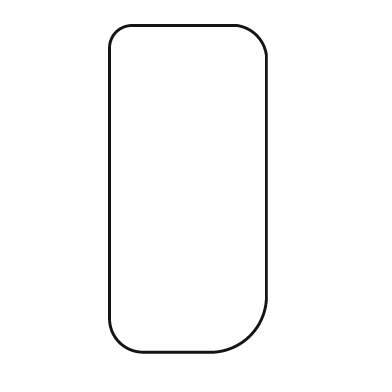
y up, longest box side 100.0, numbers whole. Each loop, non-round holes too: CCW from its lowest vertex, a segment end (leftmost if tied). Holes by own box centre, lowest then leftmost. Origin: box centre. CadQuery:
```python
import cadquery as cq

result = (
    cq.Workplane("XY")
    .moveTo(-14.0, -50.0)
    .lineTo(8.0, -50.0)
    .threePointArc((19.0, -45.0), (24.0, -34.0))
    .lineTo(24.0, 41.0)
    .threePointArc((21.0, 47.0), (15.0, 50.0))
    .lineTo(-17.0, 50.0)
    .threePointArc((-22.0, 48.0), (-24.0, 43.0))
    .lineTo(-24.0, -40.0)
    .threePointArc((-21.0, -47.0), (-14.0, -50.0))
    .close()
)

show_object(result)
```